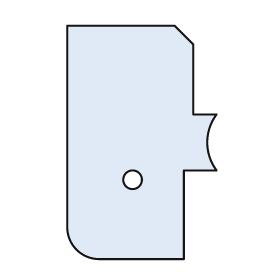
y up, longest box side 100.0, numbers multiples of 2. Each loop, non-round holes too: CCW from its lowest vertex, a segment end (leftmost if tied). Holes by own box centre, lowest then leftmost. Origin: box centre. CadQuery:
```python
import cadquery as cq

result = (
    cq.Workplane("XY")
    .moveTo(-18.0, -50.0)
    .lineTo(18.0, -50.0)
    .lineTo(18.0, -12.0)
    .lineTo(32.0, -12.0)
    .threePointArc((28.0, 0.0), (32.0, 12.0))
    .lineTo(22.0, 12.0)
    .lineTo(22.0, 42.0)
    .lineTo(14.0, 50.0)
    .lineTo(-32.0, 50.0)
    .lineTo(-32.0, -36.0)
    .threePointArc((-28.0, -46.0), (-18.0, -50.0))
    .close()
    .moveTo(-4.0, -16.0)
    .circle(4.0)
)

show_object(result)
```